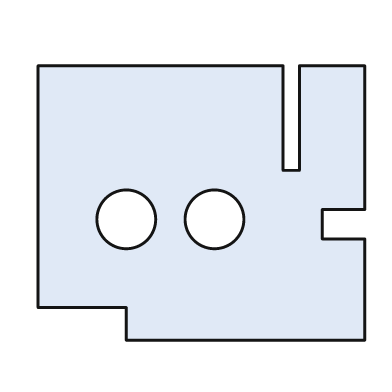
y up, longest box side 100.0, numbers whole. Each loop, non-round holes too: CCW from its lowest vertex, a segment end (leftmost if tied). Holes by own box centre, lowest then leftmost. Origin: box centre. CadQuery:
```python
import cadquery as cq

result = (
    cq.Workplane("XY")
    .moveTo(-23.0, -42.0)
    .lineTo(50.0, -42.0)
    .lineTo(50.0, -11.0)
    .lineTo(37.0, -11.0)
    .lineTo(37.0, -2.0)
    .lineTo(50.0, -2.0)
    .lineTo(50.0, 42.0)
    .lineTo(30.0, 42.0)
    .lineTo(30.0, 10.0)
    .lineTo(25.0, 10.0)
    .lineTo(25.0, 42.0)
    .lineTo(-50.0, 42.0)
    .lineTo(-50.0, -32.0)
    .lineTo(-23.0, -32.0)
    .close()
    .moveTo(-23.0, -5.0)
    .circle(9.0)
    .moveTo(4.0, -5.0)
    .circle(9.0)
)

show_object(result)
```